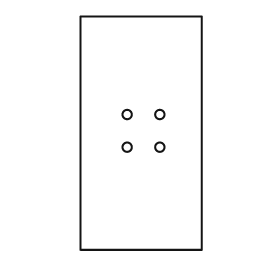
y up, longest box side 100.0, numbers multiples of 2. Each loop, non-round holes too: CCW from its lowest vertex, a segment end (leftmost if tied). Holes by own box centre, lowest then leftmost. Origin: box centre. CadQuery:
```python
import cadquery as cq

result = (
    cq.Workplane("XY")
    .moveTo(-26.0, -50.0)
    .lineTo(26.0, -50.0)
    .lineTo(26.0, 50.0)
    .lineTo(-26.0, 50.0)
    .close()
    .moveTo(-6.0, -6.0)
    .circle(2.0)
    .moveTo(8.0, -6.0)
    .circle(2.0)
    .moveTo(-6.0, 8.0)
    .circle(2.0)
    .moveTo(8.0, 8.0)
    .circle(2.0)
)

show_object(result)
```